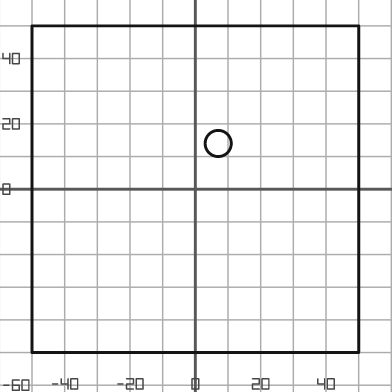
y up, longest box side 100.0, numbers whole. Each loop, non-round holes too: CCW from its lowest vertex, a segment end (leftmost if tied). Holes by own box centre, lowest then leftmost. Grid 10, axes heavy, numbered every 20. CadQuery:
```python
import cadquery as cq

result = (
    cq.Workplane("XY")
    .moveTo(-50.0, -50.0)
    .lineTo(50.0, -50.0)
    .lineTo(50.0, 50.0)
    .lineTo(-50.0, 50.0)
    .close()
    .moveTo(7.0, 14.0)
    .circle(4.0)
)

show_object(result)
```